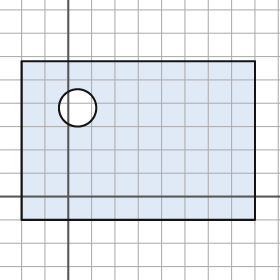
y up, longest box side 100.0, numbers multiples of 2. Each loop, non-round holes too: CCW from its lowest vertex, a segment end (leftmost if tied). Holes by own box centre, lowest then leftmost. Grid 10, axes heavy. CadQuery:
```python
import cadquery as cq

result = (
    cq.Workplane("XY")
    .moveTo(-20.0, -10.0)
    .lineTo(80.0, -10.0)
    .lineTo(80.0, 58.0)
    .lineTo(-20.0, 58.0)
    .close()
    .moveTo(4.0, 38.0)
    .circle(8.0)
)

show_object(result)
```